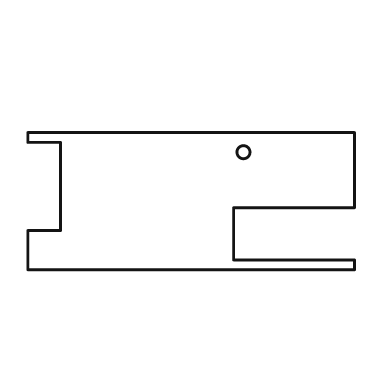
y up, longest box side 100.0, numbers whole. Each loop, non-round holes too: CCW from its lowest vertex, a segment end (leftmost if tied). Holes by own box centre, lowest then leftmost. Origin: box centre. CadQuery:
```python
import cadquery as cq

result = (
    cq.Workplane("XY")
    .moveTo(-50.0, -21.0)
    .lineTo(50.0, -21.0)
    .lineTo(50.0, -18.0)
    .lineTo(13.0, -18.0)
    .lineTo(13.0, -2.0)
    .lineTo(50.0, -2.0)
    .lineTo(50.0, 21.0)
    .lineTo(-50.0, 21.0)
    .lineTo(-50.0, 18.0)
    .lineTo(-40.0, 18.0)
    .lineTo(-40.0, -9.0)
    .lineTo(-50.0, -9.0)
    .close()
    .moveTo(16.0, 15.0)
    .circle(2.0)
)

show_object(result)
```